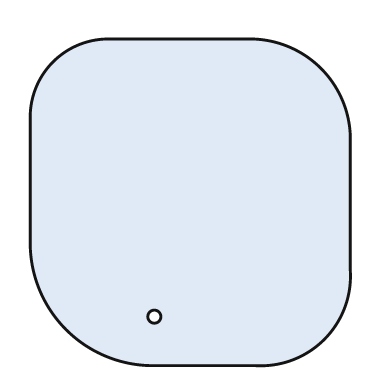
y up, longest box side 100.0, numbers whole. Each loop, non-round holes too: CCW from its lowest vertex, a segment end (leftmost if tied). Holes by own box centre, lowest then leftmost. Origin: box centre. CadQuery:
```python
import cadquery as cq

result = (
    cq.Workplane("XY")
    .moveTo(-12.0, -50.0)
    .lineTo(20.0, -50.0)
    .threePointArc((41.0, -42.0), (49.0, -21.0))
    .lineTo(49.0, 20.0)
    .threePointArc((40.0, 41.0), (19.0, 50.0))
    .lineTo(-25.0, 50.0)
    .threePointArc((-42.0, 43.0), (-49.0, 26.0))
    .lineTo(-49.0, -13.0)
    .threePointArc((-38.0, -39.0), (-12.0, -50.0))
    .close()
    .moveTo(-11.0, -35.0)
    .circle(2.0)
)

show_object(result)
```